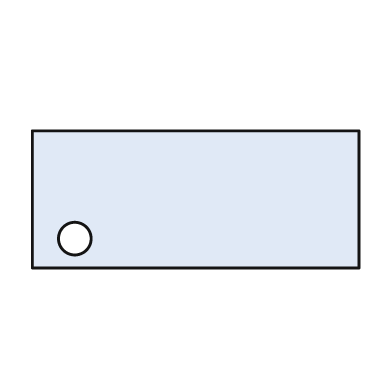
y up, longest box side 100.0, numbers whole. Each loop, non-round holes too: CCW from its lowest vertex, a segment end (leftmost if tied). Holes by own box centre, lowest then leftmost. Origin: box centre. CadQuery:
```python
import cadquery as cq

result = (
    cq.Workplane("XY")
    .moveTo(-50.0, -21.0)
    .lineTo(50.0, -21.0)
    .lineTo(50.0, 21.0)
    .lineTo(-50.0, 21.0)
    .close()
    .moveTo(-37.0, -12.0)
    .circle(5.0)
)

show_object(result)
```